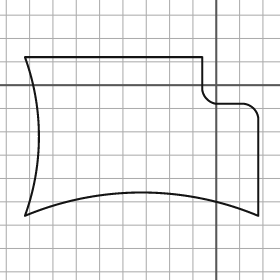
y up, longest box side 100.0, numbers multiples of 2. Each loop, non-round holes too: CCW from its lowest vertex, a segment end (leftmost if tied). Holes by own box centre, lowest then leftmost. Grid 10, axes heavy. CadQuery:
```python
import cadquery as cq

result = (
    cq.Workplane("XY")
    .moveTo(-82.0, -56.0)
    .threePointArc((-32.0, -46.0), (18.0, -56.0))
    .lineTo(18.0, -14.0)
    .threePointArc((16.0, -10.0), (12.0, -8.0))
    .lineTo(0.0, -8.0)
    .threePointArc((-4.0, -6.0), (-6.0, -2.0))
    .lineTo(-6.0, 12.0)
    .lineTo(-82.0, 12.0)
    .threePointArc((-76.0, -22.0), (-82.0, -56.0))
    .close()
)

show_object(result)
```